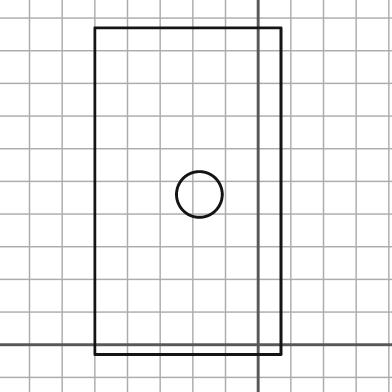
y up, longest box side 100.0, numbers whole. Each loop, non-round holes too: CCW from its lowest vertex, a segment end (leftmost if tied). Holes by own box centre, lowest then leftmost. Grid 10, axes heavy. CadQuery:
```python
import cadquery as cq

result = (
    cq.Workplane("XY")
    .moveTo(-50.0, -3.0)
    .lineTo(7.0, -3.0)
    .lineTo(7.0, 97.0)
    .lineTo(-50.0, 97.0)
    .close()
    .moveTo(-18.0, 46.0)
    .circle(7.0)
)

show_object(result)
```